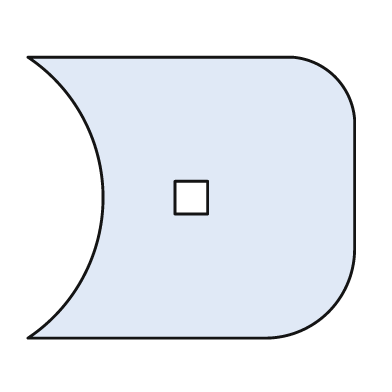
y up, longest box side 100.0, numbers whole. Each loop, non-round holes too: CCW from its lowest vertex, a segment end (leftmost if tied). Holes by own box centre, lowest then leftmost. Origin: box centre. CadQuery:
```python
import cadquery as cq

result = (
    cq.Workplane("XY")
    .moveTo(-50.0, -43.0)
    .lineTo(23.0, -43.0)
    .threePointArc((42.0, -35.0), (50.0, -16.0))
    .lineTo(50.0, 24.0)
    .threePointArc((44.0, 37.0), (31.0, 43.0))
    .lineTo(-50.0, 43.0)
    .threePointArc((-27.0, 0.0), (-50.0, -43.0))
    .close()
    .moveTo(-5.0, -5.0)
    .lineTo(5.0, -5.0)
    .lineTo(5.0, 5.0)
    .lineTo(-5.0, 5.0)
    .close()
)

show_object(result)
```